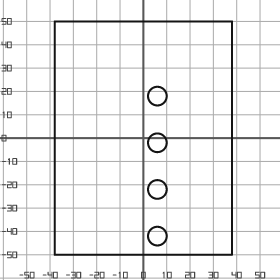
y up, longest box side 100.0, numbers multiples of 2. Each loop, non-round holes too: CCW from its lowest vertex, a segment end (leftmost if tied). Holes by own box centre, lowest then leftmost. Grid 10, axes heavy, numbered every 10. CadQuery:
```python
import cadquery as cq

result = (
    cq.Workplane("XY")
    .moveTo(-38.0, -50.0)
    .lineTo(38.0, -50.0)
    .lineTo(38.0, 50.0)
    .lineTo(-38.0, 50.0)
    .close()
    .moveTo(6.0, -42.0)
    .circle(4.0)
    .moveTo(6.0, -22.0)
    .circle(4.0)
    .moveTo(6.0, -2.0)
    .circle(4.0)
    .moveTo(6.0, 18.0)
    .circle(4.0)
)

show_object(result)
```